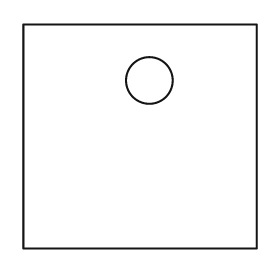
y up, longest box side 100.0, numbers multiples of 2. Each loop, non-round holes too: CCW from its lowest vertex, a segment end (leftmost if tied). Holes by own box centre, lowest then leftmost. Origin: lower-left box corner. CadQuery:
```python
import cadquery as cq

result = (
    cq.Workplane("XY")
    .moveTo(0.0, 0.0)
    .lineTo(100.0, 0.0)
    .lineTo(100.0, 96.0)
    .lineTo(0.0, 96.0)
    .close()
    .moveTo(54.0, 72.0)
    .circle(10.0)
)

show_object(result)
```